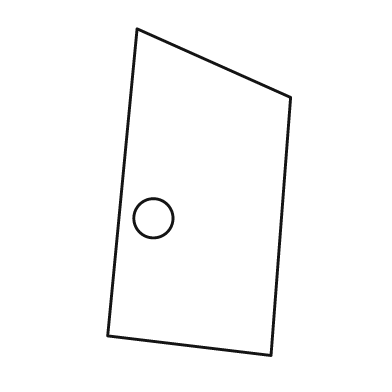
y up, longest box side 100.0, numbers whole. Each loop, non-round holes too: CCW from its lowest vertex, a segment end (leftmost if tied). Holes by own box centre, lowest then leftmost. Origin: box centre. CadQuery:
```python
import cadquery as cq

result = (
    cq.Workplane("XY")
    .moveTo(22.0, -50.0)
    .lineTo(28.0, 29.0)
    .lineTo(-19.0, 50.0)
    .lineTo(-28.0, -44.0)
    .close()
    .moveTo(-14.0, -8.0)
    .circle(6.0)
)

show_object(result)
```